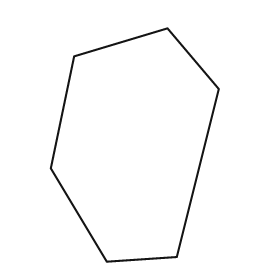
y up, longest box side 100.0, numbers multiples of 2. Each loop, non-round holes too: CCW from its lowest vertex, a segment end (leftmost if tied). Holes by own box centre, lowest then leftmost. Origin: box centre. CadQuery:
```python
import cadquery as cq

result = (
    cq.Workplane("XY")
    .moveTo(-12.0, -50.0)
    .lineTo(18.0, -48.0)
    .lineTo(36.0, 24.0)
    .lineTo(14.0, 50.0)
    .lineTo(-26.0, 38.0)
    .lineTo(-36.0, -10.0)
    .close()
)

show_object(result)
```